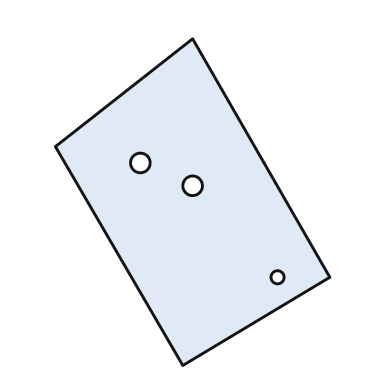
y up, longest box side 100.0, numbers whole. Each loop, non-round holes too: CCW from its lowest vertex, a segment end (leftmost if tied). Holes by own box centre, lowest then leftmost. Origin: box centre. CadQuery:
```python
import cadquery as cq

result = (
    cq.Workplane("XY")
    .moveTo(-3.0, -50.0)
    .lineTo(42.0, -23.0)
    .lineTo(0.0, 50.0)
    .lineTo(-42.0, 17.0)
    .close()
    .moveTo(26.0, -23.0)
    .circle(2.0)
    .moveTo(0.0, 5.0)
    .circle(3.0)
    .moveTo(-16.0, 12.0)
    .circle(3.0)
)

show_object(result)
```